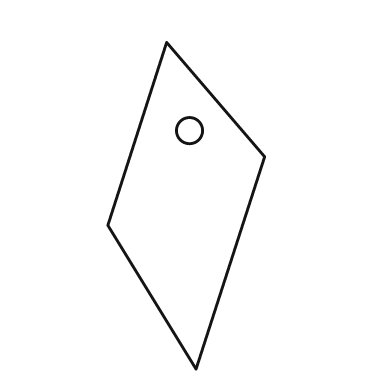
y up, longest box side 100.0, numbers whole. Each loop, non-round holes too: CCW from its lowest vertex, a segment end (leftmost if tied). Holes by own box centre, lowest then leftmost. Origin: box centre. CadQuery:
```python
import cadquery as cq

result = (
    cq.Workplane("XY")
    .moveTo(3.0, -50.0)
    .lineTo(24.0, 15.0)
    .lineTo(-6.0, 50.0)
    .lineTo(-24.0, -6.0)
    .close()
    .moveTo(1.0, 23.0)
    .circle(4.0)
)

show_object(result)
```